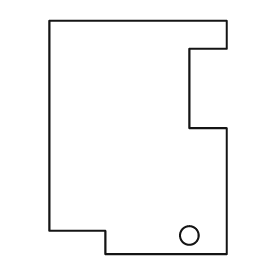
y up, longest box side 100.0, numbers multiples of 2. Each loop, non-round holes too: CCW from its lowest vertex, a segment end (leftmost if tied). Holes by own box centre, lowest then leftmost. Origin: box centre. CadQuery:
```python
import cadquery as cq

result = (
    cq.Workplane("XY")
    .moveTo(-14.0, -50.0)
    .lineTo(38.0, -50.0)
    .lineTo(38.0, 4.0)
    .lineTo(22.0, 4.0)
    .lineTo(22.0, 38.0)
    .lineTo(38.0, 38.0)
    .lineTo(38.0, 50.0)
    .lineTo(-38.0, 50.0)
    .lineTo(-38.0, -40.0)
    .lineTo(-14.0, -40.0)
    .close()
    .moveTo(22.0, -42.0)
    .circle(4.0)
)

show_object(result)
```